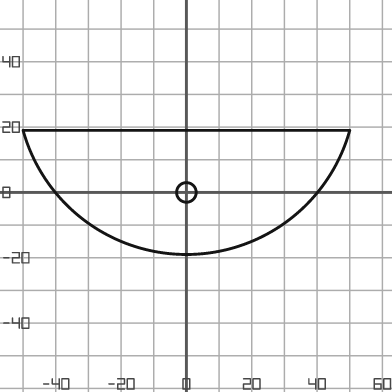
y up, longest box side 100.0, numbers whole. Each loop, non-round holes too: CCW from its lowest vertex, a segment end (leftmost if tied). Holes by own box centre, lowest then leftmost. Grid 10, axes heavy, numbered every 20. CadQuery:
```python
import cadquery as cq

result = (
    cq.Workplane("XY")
    .moveTo(-50.0, 19.0)
    .threePointArc((0.0, -19.0), (50.0, 19.0))
    .close()
    .moveTo(0.0, 0.0)
    .circle(3.0)
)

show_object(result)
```